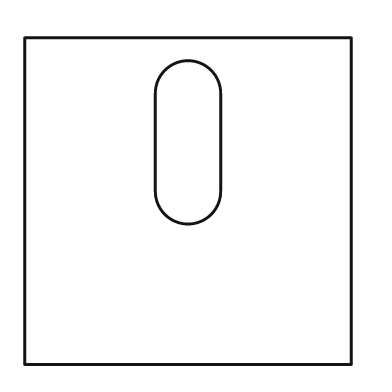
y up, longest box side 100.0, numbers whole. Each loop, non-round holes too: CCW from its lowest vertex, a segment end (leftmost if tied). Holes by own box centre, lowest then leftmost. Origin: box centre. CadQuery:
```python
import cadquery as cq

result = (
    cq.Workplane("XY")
    .moveTo(-50.0, -50.0)
    .lineTo(50.0, -50.0)
    .lineTo(50.0, 50.0)
    .lineTo(-50.0, 50.0)
    .close()
    .moveTo(-10.0, 3.0)
    .threePointArc((0.0, -7.0), (10.0, 3.0))
    .lineTo(10.0, 33.0)
    .threePointArc((0.0, 43.0), (-10.0, 33.0))
    .close()
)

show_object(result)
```